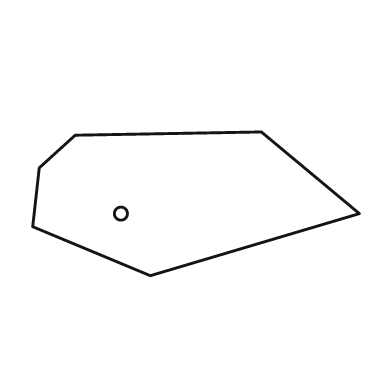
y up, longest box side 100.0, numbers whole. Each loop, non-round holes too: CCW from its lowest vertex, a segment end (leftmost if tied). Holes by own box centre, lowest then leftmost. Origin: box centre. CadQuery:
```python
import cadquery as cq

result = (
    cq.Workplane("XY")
    .moveTo(-14.0, -22.0)
    .lineTo(50.0, -3.0)
    .lineTo(20.0, 22.0)
    .lineTo(-37.0, 21.0)
    .lineTo(-48.0, 11.0)
    .lineTo(-50.0, -7.0)
    .close()
    .moveTo(-23.0, -3.0)
    .circle(2.0)
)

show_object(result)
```